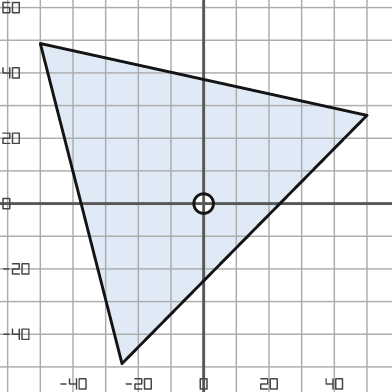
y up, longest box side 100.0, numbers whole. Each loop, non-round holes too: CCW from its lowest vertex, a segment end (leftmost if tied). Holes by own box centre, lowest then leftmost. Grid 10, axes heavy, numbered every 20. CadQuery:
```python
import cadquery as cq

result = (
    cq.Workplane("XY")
    .moveTo(-25.0, -49.0)
    .lineTo(50.0, 27.0)
    .lineTo(-50.0, 49.0)
    .close()
    .moveTo(0.0, 0.0)
    .circle(3.0)
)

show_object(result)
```